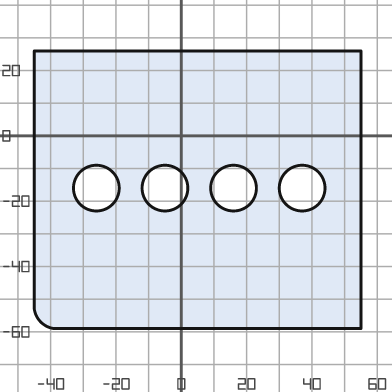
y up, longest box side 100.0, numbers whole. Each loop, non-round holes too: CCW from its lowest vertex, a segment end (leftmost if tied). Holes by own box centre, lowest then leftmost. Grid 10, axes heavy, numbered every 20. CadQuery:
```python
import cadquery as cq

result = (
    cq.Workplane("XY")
    .moveTo(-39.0, -59.0)
    .lineTo(55.0, -59.0)
    .lineTo(55.0, 26.0)
    .lineTo(-45.0, 26.0)
    .lineTo(-45.0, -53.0)
    .threePointArc((-43.0, -57.0), (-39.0, -59.0))
    .close()
    .moveTo(-26.0, -16.0)
    .circle(7.0)
    .moveTo(-5.0, -16.0)
    .circle(7.0)
    .moveTo(16.0, -16.0)
    .circle(7.0)
    .moveTo(37.0, -16.0)
    .circle(7.0)
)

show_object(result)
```